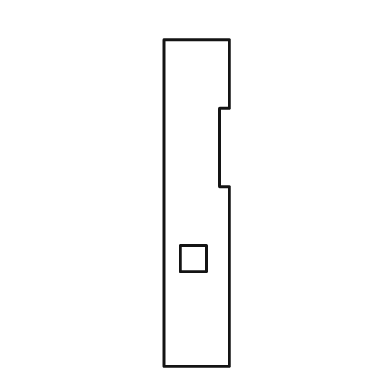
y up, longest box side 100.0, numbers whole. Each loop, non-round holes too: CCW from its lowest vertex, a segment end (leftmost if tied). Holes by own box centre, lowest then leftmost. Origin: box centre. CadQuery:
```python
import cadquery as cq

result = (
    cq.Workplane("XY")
    .moveTo(-10.0, -50.0)
    .lineTo(10.0, -50.0)
    .lineTo(10.0, 5.0)
    .lineTo(7.0, 5.0)
    .lineTo(7.0, 29.0)
    .lineTo(10.0, 29.0)
    .lineTo(10.0, 50.0)
    .lineTo(-10.0, 50.0)
    .close()
    .moveTo(-5.0, -21.0)
    .lineTo(3.0, -21.0)
    .lineTo(3.0, -13.0)
    .lineTo(-5.0, -13.0)
    .close()
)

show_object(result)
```